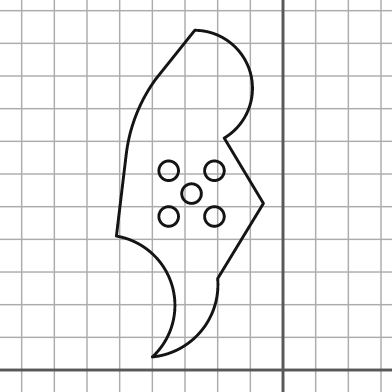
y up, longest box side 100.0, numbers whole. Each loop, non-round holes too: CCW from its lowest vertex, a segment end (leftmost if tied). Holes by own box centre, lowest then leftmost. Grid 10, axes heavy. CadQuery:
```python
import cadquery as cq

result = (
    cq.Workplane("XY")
    .moveTo(-40.0, 4.0)
    .threePointArc((-25.0, 12.0), (-20.0, 28.0))
    .lineTo(-6.0, 51.0)
    .lineTo(-18.0, 71.0)
    .threePointArc((-10.0, 91.0), (-27.0, 104.0))
    .lineTo(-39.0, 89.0)
    .threePointArc((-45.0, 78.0), (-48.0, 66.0))
    .lineTo(-51.0, 41.0)
    .threePointArc((-34.0, 26.0), (-40.0, 4.0))
    .close()
    .moveTo(-35.0, 47.0)
    .circle(3.0)
    .moveTo(-21.0, 47.0)
    .circle(3.0)
    .moveTo(-28.0, 54.0)
    .circle(3.0)
    .moveTo(-35.0, 61.0)
    .circle(3.0)
    .moveTo(-21.0, 61.0)
    .circle(3.0)
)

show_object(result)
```